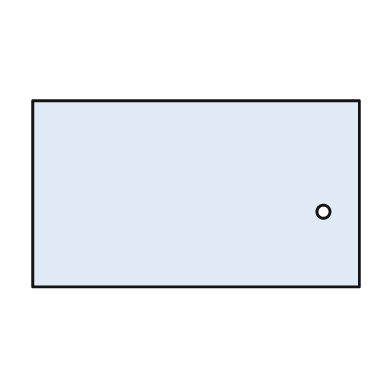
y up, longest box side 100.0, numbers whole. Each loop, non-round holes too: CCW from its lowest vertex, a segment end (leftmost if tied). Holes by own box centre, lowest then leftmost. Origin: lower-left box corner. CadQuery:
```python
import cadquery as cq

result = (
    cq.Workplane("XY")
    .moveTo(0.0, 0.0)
    .lineTo(100.0, 0.0)
    .lineTo(100.0, 57.0)
    .lineTo(0.0, 57.0)
    .close()
    .moveTo(89.0, 23.0)
    .circle(2.0)
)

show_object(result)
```